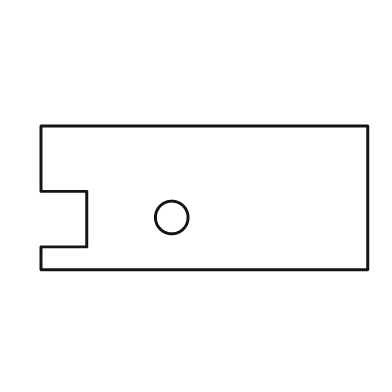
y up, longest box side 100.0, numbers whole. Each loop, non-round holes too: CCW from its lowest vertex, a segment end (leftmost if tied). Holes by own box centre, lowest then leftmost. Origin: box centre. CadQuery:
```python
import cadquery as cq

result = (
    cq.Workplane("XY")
    .moveTo(-50.0, -22.0)
    .lineTo(50.0, -22.0)
    .lineTo(50.0, 22.0)
    .lineTo(-50.0, 22.0)
    .lineTo(-50.0, 2.0)
    .lineTo(-36.0, 2.0)
    .lineTo(-36.0, -15.0)
    .lineTo(-50.0, -15.0)
    .close()
    .moveTo(-10.0, -6.0)
    .circle(5.0)
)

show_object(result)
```